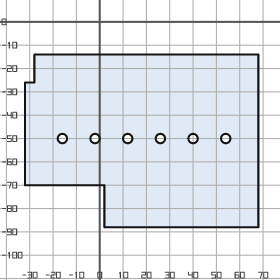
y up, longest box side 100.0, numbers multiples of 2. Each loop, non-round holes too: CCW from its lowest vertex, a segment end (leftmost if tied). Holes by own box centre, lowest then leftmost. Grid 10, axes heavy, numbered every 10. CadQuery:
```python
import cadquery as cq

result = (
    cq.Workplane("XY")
    .moveTo(2.0, -88.0)
    .lineTo(68.0, -88.0)
    .lineTo(68.0, -14.0)
    .lineTo(-28.0, -14.0)
    .lineTo(-28.0, -26.0)
    .lineTo(-32.0, -26.0)
    .lineTo(-32.0, -70.0)
    .lineTo(2.0, -70.0)
    .close()
    .moveTo(-16.0, -50.0)
    .circle(2.0)
    .moveTo(-2.0, -50.0)
    .circle(2.0)
    .moveTo(12.0, -50.0)
    .circle(2.0)
    .moveTo(26.0, -50.0)
    .circle(2.0)
    .moveTo(40.0, -50.0)
    .circle(2.0)
    .moveTo(54.0, -50.0)
    .circle(2.0)
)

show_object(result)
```